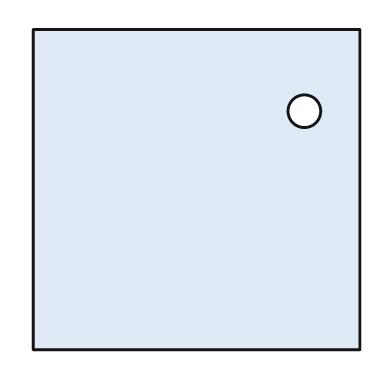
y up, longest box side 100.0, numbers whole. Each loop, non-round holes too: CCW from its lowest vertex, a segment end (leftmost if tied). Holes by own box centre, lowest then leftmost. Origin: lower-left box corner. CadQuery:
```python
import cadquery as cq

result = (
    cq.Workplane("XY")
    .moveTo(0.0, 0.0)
    .lineTo(100.0, 0.0)
    .lineTo(100.0, 98.0)
    .lineTo(0.0, 98.0)
    .close()
    .moveTo(83.0, 73.0)
    .circle(5.0)
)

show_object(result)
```